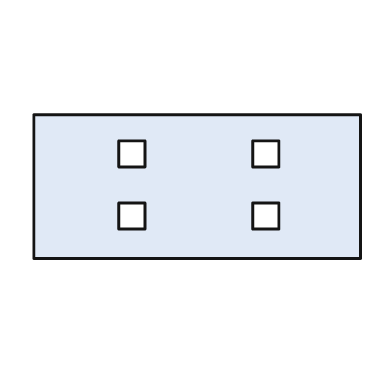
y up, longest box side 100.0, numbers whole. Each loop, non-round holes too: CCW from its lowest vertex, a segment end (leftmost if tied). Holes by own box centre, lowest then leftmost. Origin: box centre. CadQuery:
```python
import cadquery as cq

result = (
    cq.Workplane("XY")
    .moveTo(-50.0, -22.0)
    .lineTo(50.0, -22.0)
    .lineTo(50.0, 22.0)
    .lineTo(-50.0, 22.0)
    .close()
    .moveTo(-24.0, -13.0)
    .lineTo(-16.0, -13.0)
    .lineTo(-16.0, -5.0)
    .lineTo(-24.0, -5.0)
    .close()
    .moveTo(17.0, -13.0)
    .lineTo(25.0, -13.0)
    .lineTo(25.0, -5.0)
    .lineTo(17.0, -5.0)
    .close()
    .moveTo(-24.0, 6.0)
    .lineTo(-16.0, 6.0)
    .lineTo(-16.0, 14.0)
    .lineTo(-24.0, 14.0)
    .close()
    .moveTo(17.0, 6.0)
    .lineTo(25.0, 6.0)
    .lineTo(25.0, 14.0)
    .lineTo(17.0, 14.0)
    .close()
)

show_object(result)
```